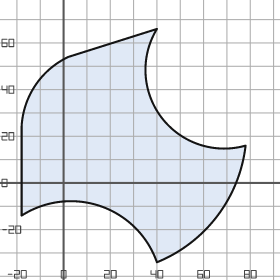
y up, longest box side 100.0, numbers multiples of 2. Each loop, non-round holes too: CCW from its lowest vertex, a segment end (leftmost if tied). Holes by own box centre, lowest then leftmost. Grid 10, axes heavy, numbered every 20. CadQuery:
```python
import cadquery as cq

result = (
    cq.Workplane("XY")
    .moveTo(40.0, -34.0)
    .threePointArc((66.0, -14.0), (78.0, 16.0))
    .threePointArc((42.0, 28.0), (40.0, 66.0))
    .lineTo(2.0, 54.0)
    .threePointArc((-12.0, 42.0), (-18.0, 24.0))
    .lineTo(-18.0, -14.0)
    .threePointArc((16.0, -10.0), (40.0, -34.0))
    .close()
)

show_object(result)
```